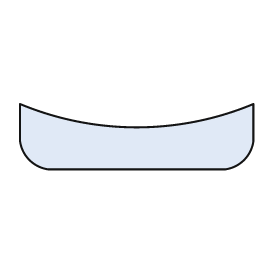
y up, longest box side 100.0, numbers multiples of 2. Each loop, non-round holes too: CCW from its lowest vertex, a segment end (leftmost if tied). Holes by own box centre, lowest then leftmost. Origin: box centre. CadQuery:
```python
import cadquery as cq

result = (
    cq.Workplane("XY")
    .moveTo(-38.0, -14.0)
    .lineTo(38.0, -14.0)
    .threePointArc((46.0, -10.0), (50.0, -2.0))
    .lineTo(50.0, 14.0)
    .threePointArc((0.0, 4.0), (-50.0, 14.0))
    .lineTo(-50.0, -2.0)
    .threePointArc((-46.0, -10.0), (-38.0, -14.0))
    .close()
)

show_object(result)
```